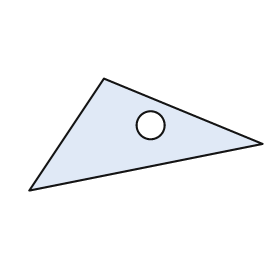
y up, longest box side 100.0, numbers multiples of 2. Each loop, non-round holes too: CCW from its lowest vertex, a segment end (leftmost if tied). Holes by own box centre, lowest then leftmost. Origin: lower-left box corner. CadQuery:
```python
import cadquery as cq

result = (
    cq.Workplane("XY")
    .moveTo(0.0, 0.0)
    .lineTo(100.0, 20.0)
    .lineTo(32.0, 48.0)
    .close()
    .moveTo(52.0, 28.0)
    .circle(6.0)
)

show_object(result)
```